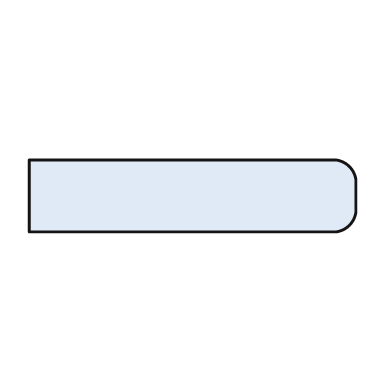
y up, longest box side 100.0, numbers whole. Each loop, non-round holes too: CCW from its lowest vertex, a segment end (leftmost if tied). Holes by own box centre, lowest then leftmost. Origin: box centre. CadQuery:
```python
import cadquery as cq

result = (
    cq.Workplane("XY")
    .moveTo(-50.0, -11.0)
    .lineTo(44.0, -11.0)
    .threePointArc((48.0, -9.0), (50.0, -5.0))
    .lineTo(50.0, 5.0)
    .threePointArc((48.0, 9.0), (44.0, 11.0))
    .lineTo(-50.0, 11.0)
    .close()
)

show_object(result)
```